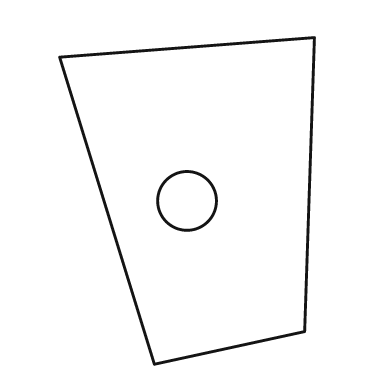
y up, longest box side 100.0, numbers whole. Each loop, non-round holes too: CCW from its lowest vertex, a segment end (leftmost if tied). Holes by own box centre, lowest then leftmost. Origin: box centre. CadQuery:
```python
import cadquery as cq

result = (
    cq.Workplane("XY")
    .moveTo(-10.0, -50.0)
    .lineTo(36.0, -40.0)
    .lineTo(39.0, 50.0)
    .lineTo(-39.0, 44.0)
    .close()
    .moveTo(0.0, 0.0)
    .circle(9.0)
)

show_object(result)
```